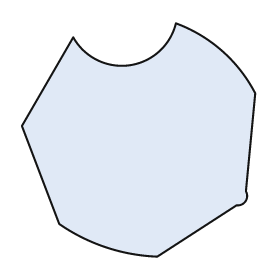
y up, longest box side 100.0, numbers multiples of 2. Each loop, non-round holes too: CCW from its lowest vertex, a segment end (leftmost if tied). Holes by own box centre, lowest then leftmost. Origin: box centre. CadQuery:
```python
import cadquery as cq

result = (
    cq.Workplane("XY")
    .moveTo(8.0, -50.0)
    .lineTo(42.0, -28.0)
    .threePointArc((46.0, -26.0), (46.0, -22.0))
    .lineTo(50.0, 20.0)
    .threePointArc((36.0, 38.0), (16.0, 50.0))
    .threePointArc((-4.0, 32.0), (-28.0, 44.0))
    .lineTo(-50.0, 6.0)
    .lineTo(-34.0, -36.0)
    .threePointArc((-14.0, -46.0), (8.0, -50.0))
    .close()
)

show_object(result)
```